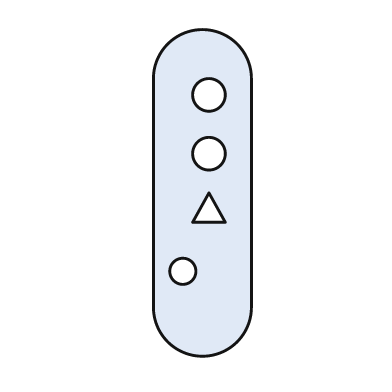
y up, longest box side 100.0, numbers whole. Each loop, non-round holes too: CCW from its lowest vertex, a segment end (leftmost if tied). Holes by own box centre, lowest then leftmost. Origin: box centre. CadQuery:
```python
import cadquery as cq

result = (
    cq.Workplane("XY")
    .moveTo(-15.0, -35.0)
    .threePointArc((0.0, -50.0), (15.0, -35.0))
    .lineTo(15.0, 35.0)
    .threePointArc((0.0, 50.0), (-15.0, 35.0))
    .close()
    .moveTo(-6.0, -24.0)
    .circle(4.0)
    .moveTo(-3.0, -9.0)
    .lineTo(7.0, -9.0)
    .lineTo(2.0, 0.0)
    .close()
    .moveTo(2.0, 12.0)
    .circle(5.0)
    .moveTo(2.0, 30.0)
    .circle(5.0)
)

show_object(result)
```